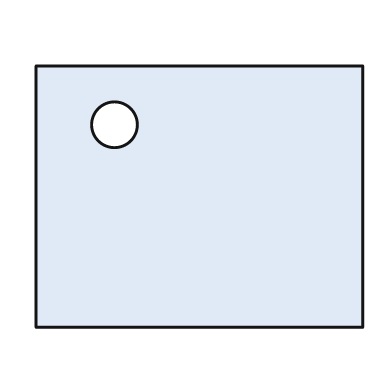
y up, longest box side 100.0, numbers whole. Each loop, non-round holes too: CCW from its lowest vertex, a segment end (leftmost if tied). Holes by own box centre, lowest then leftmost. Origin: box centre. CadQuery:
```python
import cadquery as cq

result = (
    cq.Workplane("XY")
    .moveTo(-50.0, -40.0)
    .lineTo(50.0, -40.0)
    .lineTo(50.0, 40.0)
    .lineTo(-50.0, 40.0)
    .close()
    .moveTo(-26.0, 22.0)
    .circle(7.0)
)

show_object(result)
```